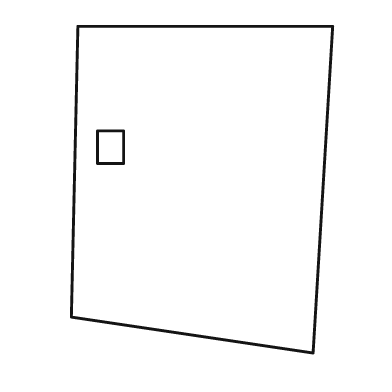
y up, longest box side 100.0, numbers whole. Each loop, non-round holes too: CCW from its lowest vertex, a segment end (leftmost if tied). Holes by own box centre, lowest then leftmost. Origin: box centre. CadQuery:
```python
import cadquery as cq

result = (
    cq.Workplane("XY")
    .moveTo(34.0, -50.0)
    .lineTo(40.0, 50.0)
    .lineTo(-38.0, 50.0)
    .lineTo(-40.0, -39.0)
    .close()
    .moveTo(-32.0, 8.0)
    .lineTo(-24.0, 8.0)
    .lineTo(-24.0, 18.0)
    .lineTo(-32.0, 18.0)
    .close()
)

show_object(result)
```